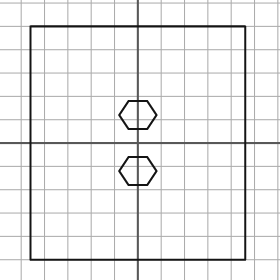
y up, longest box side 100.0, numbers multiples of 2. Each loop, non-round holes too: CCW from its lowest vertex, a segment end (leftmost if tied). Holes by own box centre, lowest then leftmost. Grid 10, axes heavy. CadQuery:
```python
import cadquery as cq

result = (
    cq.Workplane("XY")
    .moveTo(-46.0, -50.0)
    .lineTo(46.0, -50.0)
    .lineTo(46.0, 50.0)
    .lineTo(-46.0, 50.0)
    .close()
    .moveTo(-4.0, -18.0)
    .lineTo(4.0, -18.0)
    .lineTo(8.0, -12.0)
    .lineTo(4.0, -6.0)
    .lineTo(-4.0, -6.0)
    .lineTo(-8.0, -12.0)
    .close()
    .moveTo(-4.0, 6.0)
    .lineTo(4.0, 6.0)
    .lineTo(8.0, 12.0)
    .lineTo(4.0, 18.0)
    .lineTo(-4.0, 18.0)
    .lineTo(-8.0, 12.0)
    .close()
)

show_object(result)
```